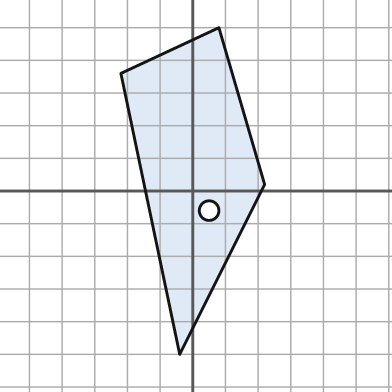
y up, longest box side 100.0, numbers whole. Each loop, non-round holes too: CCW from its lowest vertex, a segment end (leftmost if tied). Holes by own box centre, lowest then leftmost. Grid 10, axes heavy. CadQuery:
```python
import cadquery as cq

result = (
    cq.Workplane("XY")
    .moveTo(-4.0, -50.0)
    .lineTo(22.0, 2.0)
    .lineTo(8.0, 50.0)
    .lineTo(-22.0, 36.0)
    .close()
    .moveTo(5.0, -6.0)
    .circle(3.0)
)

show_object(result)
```